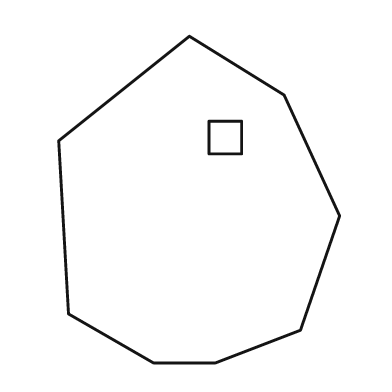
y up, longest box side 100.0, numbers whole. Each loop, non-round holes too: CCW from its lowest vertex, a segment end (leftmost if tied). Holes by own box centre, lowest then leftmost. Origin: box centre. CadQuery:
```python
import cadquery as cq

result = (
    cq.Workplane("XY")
    .moveTo(-14.0, -50.0)
    .lineTo(5.0, -50.0)
    .lineTo(31.0, -40.0)
    .lineTo(43.0, -5.0)
    .lineTo(26.0, 32.0)
    .lineTo(-3.0, 50.0)
    .lineTo(-43.0, 18.0)
    .lineTo(-40.0, -35.0)
    .close()
    .moveTo(3.0, 14.0)
    .lineTo(13.0, 14.0)
    .lineTo(13.0, 24.0)
    .lineTo(3.0, 24.0)
    .close()
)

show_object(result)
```